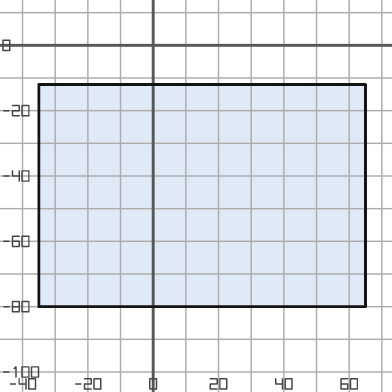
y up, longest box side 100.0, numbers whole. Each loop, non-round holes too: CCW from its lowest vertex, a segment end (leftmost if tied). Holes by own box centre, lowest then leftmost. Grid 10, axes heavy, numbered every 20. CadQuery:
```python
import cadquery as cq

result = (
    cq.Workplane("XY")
    .moveTo(-35.0, -80.0)
    .lineTo(65.0, -80.0)
    .lineTo(65.0, -12.0)
    .lineTo(-35.0, -12.0)
    .close()
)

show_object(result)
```